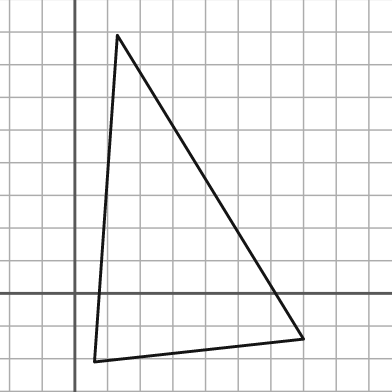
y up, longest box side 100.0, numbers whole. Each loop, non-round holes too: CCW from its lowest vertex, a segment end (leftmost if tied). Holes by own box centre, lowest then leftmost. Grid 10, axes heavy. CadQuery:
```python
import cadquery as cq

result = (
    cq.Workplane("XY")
    .moveTo(6.0, -21.0)
    .lineTo(70.0, -14.0)
    .lineTo(13.0, 79.0)
    .close()
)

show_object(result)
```